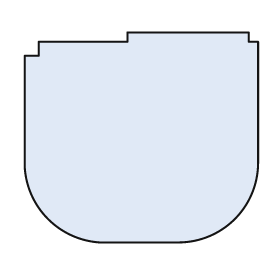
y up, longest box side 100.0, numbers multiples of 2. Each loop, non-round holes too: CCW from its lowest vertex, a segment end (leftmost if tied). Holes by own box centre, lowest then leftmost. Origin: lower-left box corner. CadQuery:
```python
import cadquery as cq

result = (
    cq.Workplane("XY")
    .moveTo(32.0, 0.0)
    .lineTo(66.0, 0.0)
    .threePointArc((90.0, 10.0), (100.0, 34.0))
    .lineTo(100.0, 86.0)
    .lineTo(96.0, 86.0)
    .lineTo(96.0, 90.0)
    .lineTo(44.0, 90.0)
    .lineTo(44.0, 86.0)
    .lineTo(6.0, 86.0)
    .lineTo(6.0, 80.0)
    .lineTo(0.0, 80.0)
    .lineTo(0.0, 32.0)
    .threePointArc((10.0, 10.0), (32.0, 0.0))
    .close()
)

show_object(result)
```